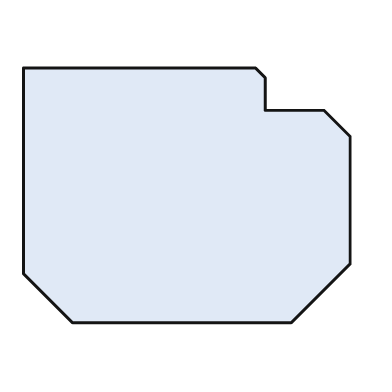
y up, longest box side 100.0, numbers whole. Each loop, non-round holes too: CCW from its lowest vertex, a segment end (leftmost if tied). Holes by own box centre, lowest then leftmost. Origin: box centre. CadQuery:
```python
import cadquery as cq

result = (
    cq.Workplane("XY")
    .moveTo(-35.0, -39.0)
    .lineTo(32.0, -39.0)
    .lineTo(50.0, -21.0)
    .lineTo(50.0, 18.0)
    .lineTo(42.0, 26.0)
    .lineTo(24.0, 26.0)
    .lineTo(24.0, 36.0)
    .lineTo(21.0, 39.0)
    .lineTo(-50.0, 39.0)
    .lineTo(-50.0, -24.0)
    .close()
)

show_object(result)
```